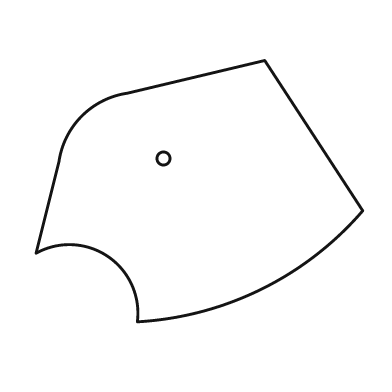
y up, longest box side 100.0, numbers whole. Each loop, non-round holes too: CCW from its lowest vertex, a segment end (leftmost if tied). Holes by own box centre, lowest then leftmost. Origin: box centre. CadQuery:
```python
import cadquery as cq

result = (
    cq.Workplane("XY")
    .moveTo(-19.0, -40.0)
    .threePointArc((19.0, -30.0), (50.0, -6.0))
    .lineTo(20.0, 40.0)
    .lineTo(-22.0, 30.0)
    .threePointArc((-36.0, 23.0), (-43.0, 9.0))
    .lineTo(-50.0, -19.0)
    .threePointArc((-28.0, -20.0), (-19.0, -40.0))
    .close()
    .moveTo(-11.0, 10.0)
    .circle(2.0)
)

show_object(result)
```